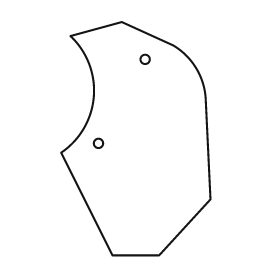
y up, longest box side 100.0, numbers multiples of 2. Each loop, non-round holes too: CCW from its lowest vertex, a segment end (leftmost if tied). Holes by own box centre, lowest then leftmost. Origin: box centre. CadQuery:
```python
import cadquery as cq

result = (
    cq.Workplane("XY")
    .moveTo(-10.0, -50.0)
    .lineTo(10.0, -50.0)
    .lineTo(32.0, -26.0)
    .lineTo(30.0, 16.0)
    .threePointArc((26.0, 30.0), (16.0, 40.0))
    .lineTo(-6.0, 50.0)
    .lineTo(-28.0, 44.0)
    .threePointArc((-18.0, 18.0), (-32.0, -6.0))
    .close()
    .moveTo(-16.0, -2.0)
    .circle(2.0)
    .moveTo(4.0, 34.0)
    .circle(2.0)
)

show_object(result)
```